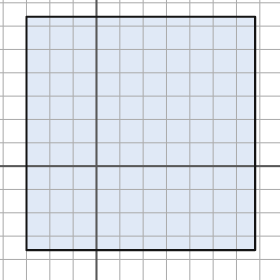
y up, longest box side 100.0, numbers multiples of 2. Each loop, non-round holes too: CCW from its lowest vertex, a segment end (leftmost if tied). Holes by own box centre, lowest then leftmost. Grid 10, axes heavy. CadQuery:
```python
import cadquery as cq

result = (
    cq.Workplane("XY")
    .moveTo(-30.0, -36.0)
    .lineTo(68.0, -36.0)
    .lineTo(68.0, 64.0)
    .lineTo(-30.0, 64.0)
    .close()
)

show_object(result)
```